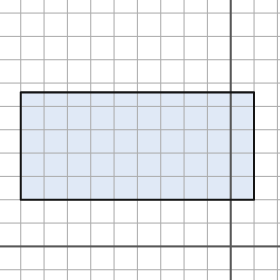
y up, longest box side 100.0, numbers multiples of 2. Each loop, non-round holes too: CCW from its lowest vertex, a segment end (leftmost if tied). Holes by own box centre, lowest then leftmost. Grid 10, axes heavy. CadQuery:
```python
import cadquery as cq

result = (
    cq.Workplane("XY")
    .moveTo(-90.0, 20.0)
    .lineTo(10.0, 20.0)
    .lineTo(10.0, 66.0)
    .lineTo(-90.0, 66.0)
    .close()
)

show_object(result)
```